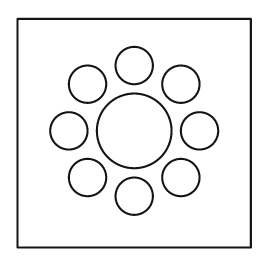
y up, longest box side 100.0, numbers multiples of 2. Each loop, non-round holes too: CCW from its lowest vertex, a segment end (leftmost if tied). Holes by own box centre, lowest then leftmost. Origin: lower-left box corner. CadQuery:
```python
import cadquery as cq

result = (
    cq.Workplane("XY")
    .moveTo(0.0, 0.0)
    .lineTo(100.0, 0.0)
    .lineTo(100.0, 98.0)
    .lineTo(0.0, 98.0)
    .close()
    .moveTo(50.0, 22.0)
    .circle(8.0)
    .moveTo(30.0, 30.0)
    .circle(8.0)
    .moveTo(70.0, 30.0)
    .circle(8.0)
    .moveTo(22.0, 50.0)
    .circle(8.0)
    .moveTo(50.0, 50.0)
    .circle(16.0)
    .moveTo(78.0, 50.0)
    .circle(8.0)
    .moveTo(30.0, 70.0)
    .circle(8.0)
    .moveTo(70.0, 70.0)
    .circle(8.0)
    .moveTo(50.0, 78.0)
    .circle(8.0)
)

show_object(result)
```